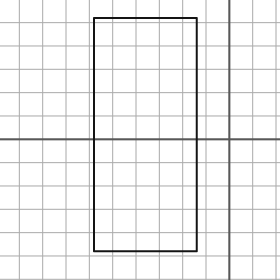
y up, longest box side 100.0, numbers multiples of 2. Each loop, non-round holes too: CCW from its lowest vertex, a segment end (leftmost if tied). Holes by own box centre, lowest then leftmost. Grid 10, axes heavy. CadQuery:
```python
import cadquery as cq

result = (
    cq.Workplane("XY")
    .moveTo(-58.0, -48.0)
    .lineTo(-14.0, -48.0)
    .lineTo(-14.0, 52.0)
    .lineTo(-58.0, 52.0)
    .close()
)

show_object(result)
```